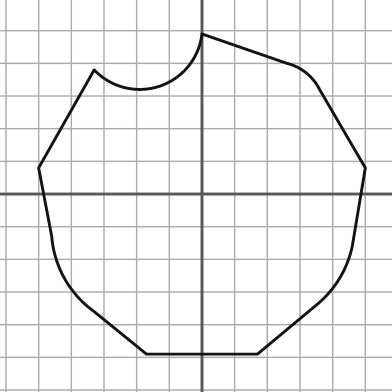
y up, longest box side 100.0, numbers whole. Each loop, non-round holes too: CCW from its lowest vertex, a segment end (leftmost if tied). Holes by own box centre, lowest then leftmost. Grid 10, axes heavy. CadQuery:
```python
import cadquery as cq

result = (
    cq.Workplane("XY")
    .moveTo(-17.0, -49.0)
    .lineTo(17.0, -49.0)
    .lineTo(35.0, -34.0)
    .threePointArc((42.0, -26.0), (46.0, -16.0))
    .lineTo(50.0, 8.0)
    .lineTo(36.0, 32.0)
    .threePointArc((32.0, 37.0), (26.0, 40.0))
    .lineTo(0.0, 49.0)
    .threePointArc((-13.0, 33.0), (-33.0, 38.0))
    .lineTo(-50.0, 8.0)
    .lineTo(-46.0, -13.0)
    .threePointArc((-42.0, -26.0), (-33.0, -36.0))
    .close()
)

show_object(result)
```